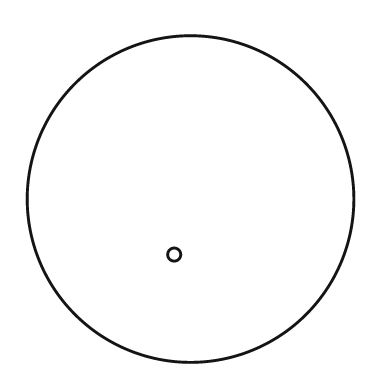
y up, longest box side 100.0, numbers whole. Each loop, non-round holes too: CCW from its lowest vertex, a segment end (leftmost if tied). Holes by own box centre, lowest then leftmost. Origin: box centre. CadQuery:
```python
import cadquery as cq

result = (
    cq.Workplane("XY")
    .moveTo(0.0, 0.0)
    .circle(50.0)
    .moveTo(-5.0, -17.0)
    .circle(2.0)
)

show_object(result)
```